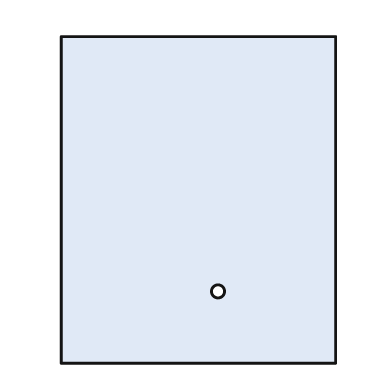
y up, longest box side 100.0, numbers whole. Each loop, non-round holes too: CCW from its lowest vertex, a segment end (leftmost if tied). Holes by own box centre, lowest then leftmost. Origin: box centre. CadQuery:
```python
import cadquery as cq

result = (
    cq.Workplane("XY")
    .moveTo(-42.0, -50.0)
    .lineTo(42.0, -50.0)
    .lineTo(42.0, 50.0)
    .lineTo(-42.0, 50.0)
    .close()
    .moveTo(6.0, -28.0)
    .circle(2.0)
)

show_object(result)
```